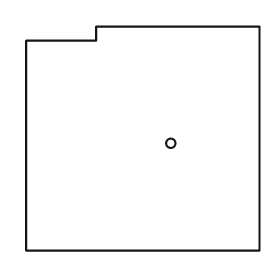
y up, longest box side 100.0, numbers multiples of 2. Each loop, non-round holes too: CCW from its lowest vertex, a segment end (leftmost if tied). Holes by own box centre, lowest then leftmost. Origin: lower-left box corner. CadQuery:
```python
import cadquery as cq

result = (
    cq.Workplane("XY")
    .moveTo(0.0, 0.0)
    .lineTo(100.0, 0.0)
    .lineTo(100.0, 96.0)
    .lineTo(30.0, 96.0)
    .lineTo(30.0, 90.0)
    .lineTo(0.0, 90.0)
    .close()
    .moveTo(62.0, 46.0)
    .circle(2.0)
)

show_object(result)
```